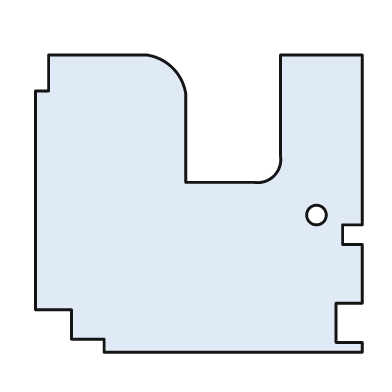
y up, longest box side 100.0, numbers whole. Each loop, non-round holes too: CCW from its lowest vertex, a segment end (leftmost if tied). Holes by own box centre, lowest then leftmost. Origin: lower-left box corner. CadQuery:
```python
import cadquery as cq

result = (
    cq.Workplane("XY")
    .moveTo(21.0, 0.0)
    .lineTo(100.0, 0.0)
    .lineTo(100.0, 3.0)
    .lineTo(92.0, 3.0)
    .lineTo(92.0, 15.0)
    .lineTo(100.0, 15.0)
    .lineTo(100.0, 33.0)
    .lineTo(94.0, 33.0)
    .lineTo(94.0, 39.0)
    .lineTo(100.0, 39.0)
    .lineTo(100.0, 91.0)
    .lineTo(75.0, 91.0)
    .lineTo(75.0, 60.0)
    .threePointArc((73.0, 54.0), (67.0, 52.0))
    .lineTo(46.0, 52.0)
    .lineTo(46.0, 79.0)
    .threePointArc((42.0, 87.0), (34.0, 91.0))
    .lineTo(4.0, 91.0)
    .lineTo(4.0, 80.0)
    .lineTo(0.0, 80.0)
    .lineTo(0.0, 13.0)
    .lineTo(11.0, 13.0)
    .lineTo(11.0, 4.0)
    .lineTo(21.0, 4.0)
    .close()
    .moveTo(86.0, 42.0)
    .circle(3.0)
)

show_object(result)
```